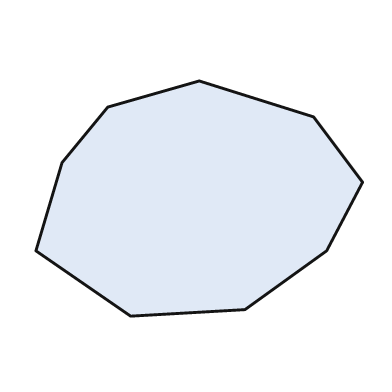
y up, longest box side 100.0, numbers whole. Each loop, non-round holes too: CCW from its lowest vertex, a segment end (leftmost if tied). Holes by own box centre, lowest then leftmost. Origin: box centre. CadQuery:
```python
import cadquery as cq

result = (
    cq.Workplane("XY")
    .moveTo(-21.0, -36.0)
    .lineTo(14.0, -34.0)
    .lineTo(39.0, -16.0)
    .lineTo(50.0, 5.0)
    .lineTo(35.0, 25.0)
    .lineTo(0.0, 36.0)
    .lineTo(-28.0, 28.0)
    .lineTo(-42.0, 11.0)
    .lineTo(-50.0, -16.0)
    .close()
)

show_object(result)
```